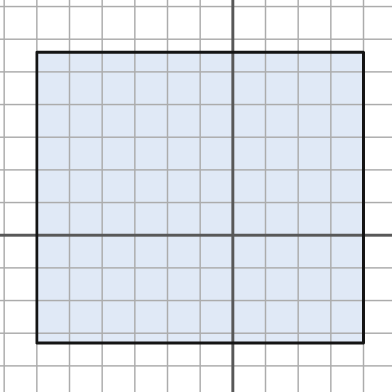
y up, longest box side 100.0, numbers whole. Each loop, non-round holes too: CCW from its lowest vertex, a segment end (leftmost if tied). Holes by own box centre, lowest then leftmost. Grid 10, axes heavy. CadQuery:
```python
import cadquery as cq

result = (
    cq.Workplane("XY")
    .moveTo(-60.0, -33.0)
    .lineTo(40.0, -33.0)
    .lineTo(40.0, 56.0)
    .lineTo(-60.0, 56.0)
    .close()
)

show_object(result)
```